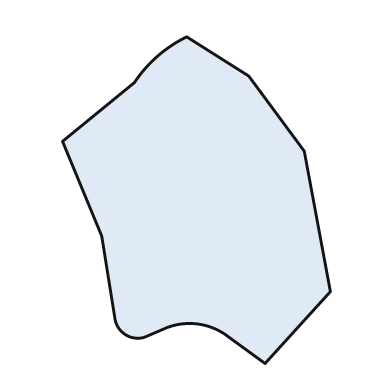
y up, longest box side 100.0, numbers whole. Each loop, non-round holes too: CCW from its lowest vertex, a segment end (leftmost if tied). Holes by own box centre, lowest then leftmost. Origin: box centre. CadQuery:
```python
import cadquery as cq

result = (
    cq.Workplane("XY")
    .moveTo(21.0, -50.0)
    .lineTo(41.0, -28.0)
    .lineTo(33.0, 15.0)
    .lineTo(16.0, 38.0)
    .lineTo(-3.0, 50.0)
    .threePointArc((-12.0, 44.0), (-19.0, 36.0))
    .lineTo(-41.0, 18.0)
    .lineTo(-29.0, -11.0)
    .lineTo(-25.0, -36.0)
    .threePointArc((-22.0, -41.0), (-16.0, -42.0))
    .lineTo(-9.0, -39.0)
    .threePointArc((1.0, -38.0), (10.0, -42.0))
    .close()
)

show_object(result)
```